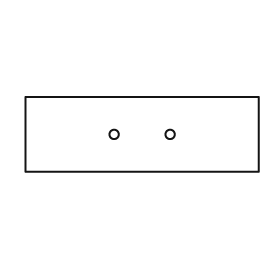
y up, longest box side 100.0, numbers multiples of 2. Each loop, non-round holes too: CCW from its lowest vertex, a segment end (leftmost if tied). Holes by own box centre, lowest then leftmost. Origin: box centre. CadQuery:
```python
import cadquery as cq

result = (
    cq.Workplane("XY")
    .moveTo(-50.0, -16.0)
    .lineTo(50.0, -16.0)
    .lineTo(50.0, 16.0)
    .lineTo(-50.0, 16.0)
    .close()
    .moveTo(-12.0, 0.0)
    .circle(2.0)
    .moveTo(12.0, 0.0)
    .circle(2.0)
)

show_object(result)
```